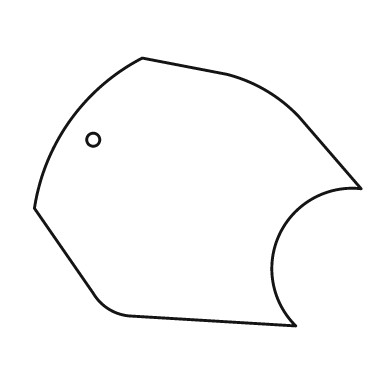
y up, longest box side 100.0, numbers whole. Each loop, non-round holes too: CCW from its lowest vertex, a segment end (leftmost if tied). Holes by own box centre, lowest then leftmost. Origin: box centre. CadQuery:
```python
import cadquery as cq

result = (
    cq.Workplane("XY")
    .moveTo(30.0, -41.0)
    .threePointArc((25.0, -13.0), (50.0, 1.0))
    .lineTo(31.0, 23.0)
    .threePointArc((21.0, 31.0), (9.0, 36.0))
    .lineTo(-17.0, 41.0)
    .threePointArc((-39.0, 22.0), (-50.0, -5.0))
    .lineTo(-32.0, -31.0)
    .threePointArc((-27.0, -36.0), (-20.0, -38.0))
    .close()
    .moveTo(-32.0, 16.0)
    .circle(2.0)
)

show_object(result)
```